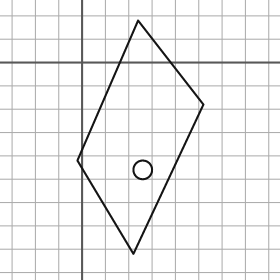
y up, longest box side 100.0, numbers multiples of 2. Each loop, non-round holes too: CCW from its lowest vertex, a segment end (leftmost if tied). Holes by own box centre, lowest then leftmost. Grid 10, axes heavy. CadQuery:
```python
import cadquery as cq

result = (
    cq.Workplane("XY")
    .moveTo(22.0, -82.0)
    .lineTo(52.0, -18.0)
    .lineTo(24.0, 18.0)
    .lineTo(-2.0, -42.0)
    .close()
    .moveTo(26.0, -46.0)
    .circle(4.0)
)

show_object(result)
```